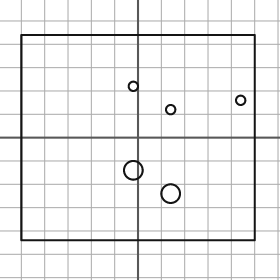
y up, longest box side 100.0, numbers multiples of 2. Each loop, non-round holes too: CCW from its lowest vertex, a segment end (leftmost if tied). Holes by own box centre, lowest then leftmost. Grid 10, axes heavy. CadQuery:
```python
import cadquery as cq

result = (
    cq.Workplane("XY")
    .moveTo(-50.0, -44.0)
    .lineTo(50.0, -44.0)
    .lineTo(50.0, 44.0)
    .lineTo(-50.0, 44.0)
    .close()
    .moveTo(14.0, -24.0)
    .circle(4.0)
    .moveTo(-2.0, -14.0)
    .circle(4.0)
    .moveTo(14.0, 12.0)
    .circle(2.0)
    .moveTo(44.0, 16.0)
    .circle(2.0)
    .moveTo(-2.0, 22.0)
    .circle(2.0)
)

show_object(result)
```